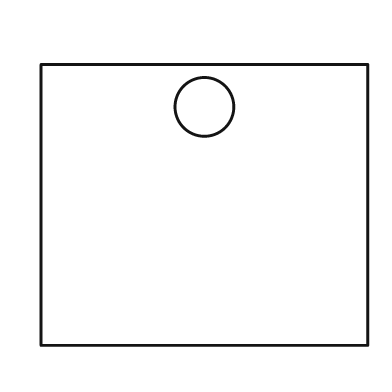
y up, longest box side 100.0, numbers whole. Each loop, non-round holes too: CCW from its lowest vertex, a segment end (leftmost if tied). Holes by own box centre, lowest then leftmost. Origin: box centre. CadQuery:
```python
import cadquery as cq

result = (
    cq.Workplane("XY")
    .moveTo(-50.0, -43.0)
    .lineTo(50.0, -43.0)
    .lineTo(50.0, 43.0)
    .lineTo(-50.0, 43.0)
    .close()
    .moveTo(0.0, 30.0)
    .circle(9.0)
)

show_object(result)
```